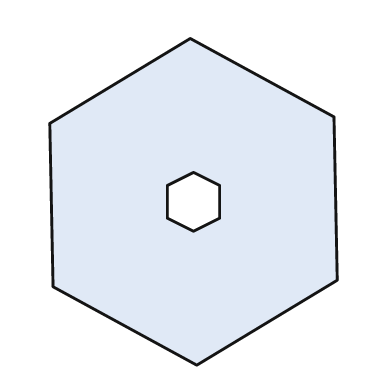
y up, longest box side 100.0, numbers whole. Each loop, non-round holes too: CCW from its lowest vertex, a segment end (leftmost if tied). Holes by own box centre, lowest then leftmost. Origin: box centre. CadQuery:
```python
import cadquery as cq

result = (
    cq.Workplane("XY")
    .moveTo(1.0, -50.0)
    .lineTo(44.0, -24.0)
    .lineTo(43.0, 26.0)
    .lineTo(-1.0, 50.0)
    .lineTo(-44.0, 24.0)
    .lineTo(-43.0, -26.0)
    .close()
    .moveTo(0.0, -9.0)
    .lineTo(8.0, -5.0)
    .lineTo(8.0, 5.0)
    .lineTo(0.0, 9.0)
    .lineTo(-8.0, 5.0)
    .lineTo(-8.0, -5.0)
    .close()
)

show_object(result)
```